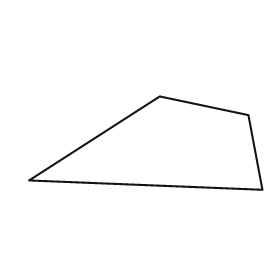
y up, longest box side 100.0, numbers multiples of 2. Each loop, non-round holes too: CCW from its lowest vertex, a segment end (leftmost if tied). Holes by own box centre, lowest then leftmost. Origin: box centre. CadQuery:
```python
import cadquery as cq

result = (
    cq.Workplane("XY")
    .moveTo(50.0, -20.0)
    .lineTo(44.0, 12.0)
    .lineTo(6.0, 20.0)
    .lineTo(-50.0, -16.0)
    .close()
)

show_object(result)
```